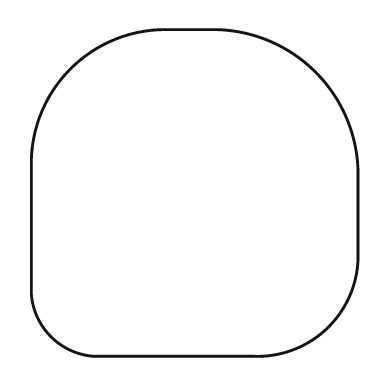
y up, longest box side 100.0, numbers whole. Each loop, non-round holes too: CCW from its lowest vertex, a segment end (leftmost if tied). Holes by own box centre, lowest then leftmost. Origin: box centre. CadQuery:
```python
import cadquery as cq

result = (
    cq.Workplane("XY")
    .moveTo(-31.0, -50.0)
    .lineTo(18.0, -50.0)
    .threePointArc((41.0, -41.0), (50.0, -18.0))
    .lineTo(50.0, 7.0)
    .threePointArc((37.0, 37.0), (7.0, 50.0))
    .lineTo(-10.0, 50.0)
    .threePointArc((-38.0, 38.0), (-50.0, 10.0))
    .lineTo(-50.0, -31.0)
    .threePointArc((-44.0, -44.0), (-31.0, -50.0))
    .close()
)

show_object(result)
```